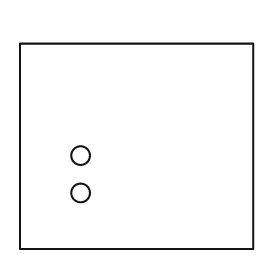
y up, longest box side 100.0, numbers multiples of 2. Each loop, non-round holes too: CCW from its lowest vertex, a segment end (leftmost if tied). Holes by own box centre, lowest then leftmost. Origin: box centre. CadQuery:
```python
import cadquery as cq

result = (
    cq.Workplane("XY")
    .moveTo(-50.0, -44.0)
    .lineTo(50.0, -44.0)
    .lineTo(50.0, 44.0)
    .lineTo(-50.0, 44.0)
    .close()
    .moveTo(-24.0, -20.0)
    .circle(4.0)
    .moveTo(-24.0, -4.0)
    .circle(4.0)
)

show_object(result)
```